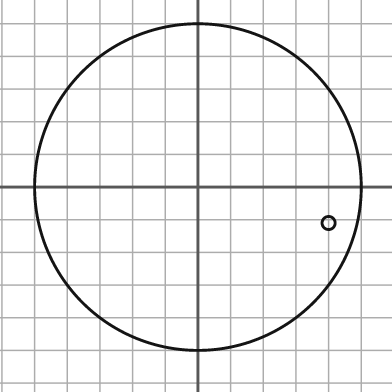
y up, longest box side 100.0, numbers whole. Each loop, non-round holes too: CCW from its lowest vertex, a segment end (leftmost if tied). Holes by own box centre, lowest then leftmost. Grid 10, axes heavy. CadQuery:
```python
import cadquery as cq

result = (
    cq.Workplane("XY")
    .moveTo(0.0, 0.0)
    .circle(50.0)
    .moveTo(40.0, -11.0)
    .circle(2.0)
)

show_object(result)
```